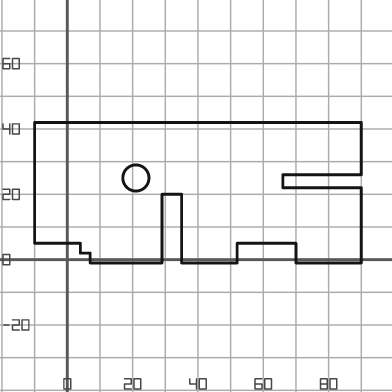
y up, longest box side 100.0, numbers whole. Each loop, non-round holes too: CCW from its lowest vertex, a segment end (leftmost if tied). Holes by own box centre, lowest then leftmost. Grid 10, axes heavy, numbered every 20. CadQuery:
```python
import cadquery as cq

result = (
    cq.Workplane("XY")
    .moveTo(7.0, -1.0)
    .lineTo(29.0, -1.0)
    .lineTo(29.0, 20.0)
    .lineTo(35.0, 20.0)
    .lineTo(35.0, -1.0)
    .lineTo(52.0, -1.0)
    .lineTo(52.0, 5.0)
    .lineTo(70.0, 5.0)
    .lineTo(70.0, -1.0)
    .lineTo(90.0, -1.0)
    .lineTo(90.0, 22.0)
    .lineTo(66.0, 22.0)
    .lineTo(66.0, 26.0)
    .lineTo(90.0, 26.0)
    .lineTo(90.0, 42.0)
    .lineTo(-10.0, 42.0)
    .lineTo(-10.0, 5.0)
    .lineTo(4.0, 5.0)
    .lineTo(4.0, 2.0)
    .lineTo(7.0, 2.0)
    .close()
    .moveTo(21.0, 25.0)
    .circle(4.0)
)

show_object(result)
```